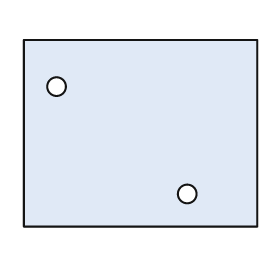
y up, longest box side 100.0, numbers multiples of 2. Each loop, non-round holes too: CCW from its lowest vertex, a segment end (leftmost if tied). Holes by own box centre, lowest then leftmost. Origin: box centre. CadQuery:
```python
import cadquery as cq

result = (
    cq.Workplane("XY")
    .moveTo(-50.0, -40.0)
    .lineTo(50.0, -40.0)
    .lineTo(50.0, 40.0)
    .lineTo(-50.0, 40.0)
    .close()
    .moveTo(20.0, -26.0)
    .circle(4.0)
    .moveTo(-36.0, 20.0)
    .circle(4.0)
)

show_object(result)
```